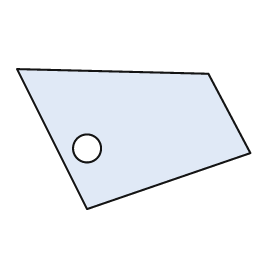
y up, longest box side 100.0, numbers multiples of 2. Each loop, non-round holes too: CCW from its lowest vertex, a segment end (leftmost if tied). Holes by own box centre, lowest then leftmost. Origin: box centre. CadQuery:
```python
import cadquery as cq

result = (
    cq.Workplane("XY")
    .moveTo(-20.0, -30.0)
    .lineTo(50.0, -6.0)
    .lineTo(32.0, 28.0)
    .lineTo(-50.0, 30.0)
    .close()
    .moveTo(-20.0, -4.0)
    .circle(6.0)
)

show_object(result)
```